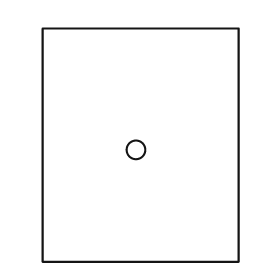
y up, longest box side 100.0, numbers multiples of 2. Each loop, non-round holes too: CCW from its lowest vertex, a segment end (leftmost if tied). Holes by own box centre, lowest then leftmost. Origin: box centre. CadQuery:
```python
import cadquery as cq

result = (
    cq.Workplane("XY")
    .moveTo(-42.0, -50.0)
    .lineTo(42.0, -50.0)
    .lineTo(42.0, 50.0)
    .lineTo(-42.0, 50.0)
    .close()
    .moveTo(-2.0, -2.0)
    .circle(4.0)
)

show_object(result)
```